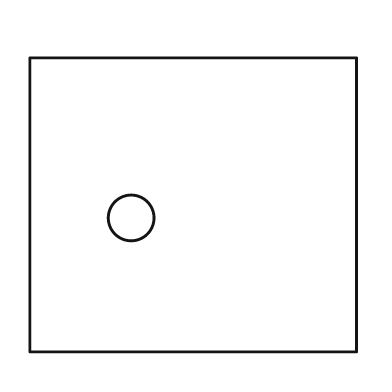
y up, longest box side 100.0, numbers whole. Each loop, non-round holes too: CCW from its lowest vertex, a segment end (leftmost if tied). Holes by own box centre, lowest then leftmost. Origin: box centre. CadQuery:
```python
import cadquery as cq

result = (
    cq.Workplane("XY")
    .moveTo(-50.0, -45.0)
    .lineTo(50.0, -45.0)
    .lineTo(50.0, 45.0)
    .lineTo(-50.0, 45.0)
    .close()
    .moveTo(-19.0, -4.0)
    .circle(7.0)
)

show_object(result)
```